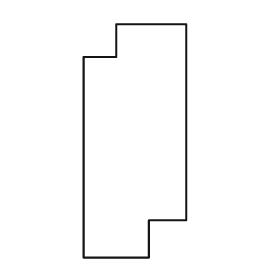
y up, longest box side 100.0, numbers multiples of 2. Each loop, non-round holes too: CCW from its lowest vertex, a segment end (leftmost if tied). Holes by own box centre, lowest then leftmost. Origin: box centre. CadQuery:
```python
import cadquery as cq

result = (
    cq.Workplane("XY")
    .moveTo(-22.0, -50.0)
    .lineTo(6.0, -50.0)
    .lineTo(6.0, -34.0)
    .lineTo(22.0, -34.0)
    .lineTo(22.0, 50.0)
    .lineTo(-8.0, 50.0)
    .lineTo(-8.0, 36.0)
    .lineTo(-22.0, 36.0)
    .close()
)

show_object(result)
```